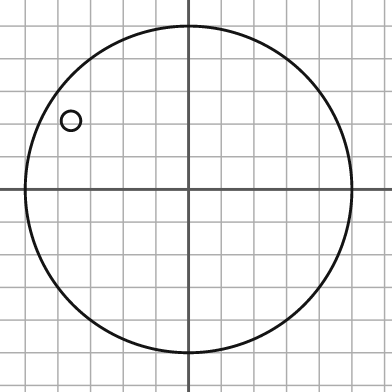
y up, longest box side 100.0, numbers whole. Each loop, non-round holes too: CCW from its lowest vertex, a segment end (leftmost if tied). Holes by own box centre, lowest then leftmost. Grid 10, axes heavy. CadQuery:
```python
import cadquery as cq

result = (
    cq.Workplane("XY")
    .moveTo(0.0, 0.0)
    .circle(50.0)
    .moveTo(-36.0, 21.0)
    .circle(3.0)
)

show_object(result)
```